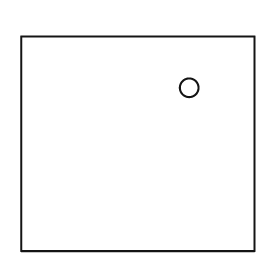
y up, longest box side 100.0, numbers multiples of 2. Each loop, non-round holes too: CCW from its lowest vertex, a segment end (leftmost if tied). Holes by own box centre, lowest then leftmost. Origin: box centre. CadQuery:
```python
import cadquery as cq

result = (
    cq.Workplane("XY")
    .moveTo(-50.0, -46.0)
    .lineTo(50.0, -46.0)
    .lineTo(50.0, 46.0)
    .lineTo(-50.0, 46.0)
    .close()
    .moveTo(22.0, 24.0)
    .circle(4.0)
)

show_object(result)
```